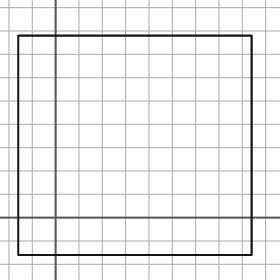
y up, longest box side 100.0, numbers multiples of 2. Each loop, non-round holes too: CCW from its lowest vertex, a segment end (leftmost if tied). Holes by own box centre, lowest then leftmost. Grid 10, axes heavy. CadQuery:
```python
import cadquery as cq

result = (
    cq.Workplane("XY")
    .moveTo(-16.0, -16.0)
    .lineTo(84.0, -16.0)
    .lineTo(84.0, 78.0)
    .lineTo(-16.0, 78.0)
    .close()
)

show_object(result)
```